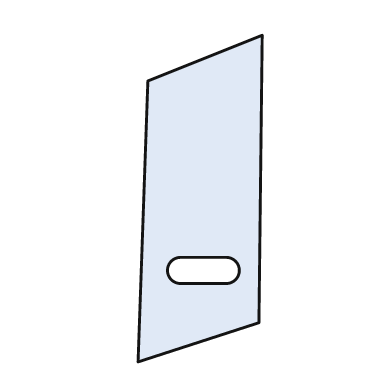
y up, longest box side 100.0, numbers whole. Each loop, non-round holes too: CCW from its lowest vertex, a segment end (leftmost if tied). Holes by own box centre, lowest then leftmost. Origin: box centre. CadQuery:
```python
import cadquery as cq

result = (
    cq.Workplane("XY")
    .moveTo(-19.0, -50.0)
    .lineTo(18.0, -38.0)
    .lineTo(19.0, 50.0)
    .lineTo(-16.0, 36.0)
    .close()
    .moveTo(-6.0, -26.0)
    .lineTo(8.0, -26.0)
    .threePointArc((12.0, -22.0), (8.0, -18.0))
    .lineTo(-6.0, -18.0)
    .threePointArc((-10.0, -22.0), (-6.0, -26.0))
    .close()
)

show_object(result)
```